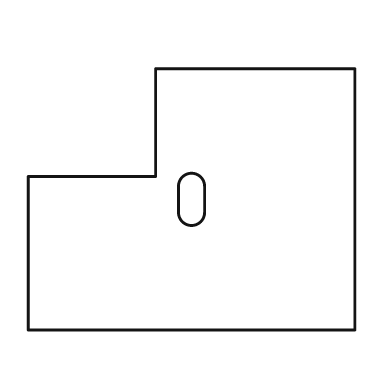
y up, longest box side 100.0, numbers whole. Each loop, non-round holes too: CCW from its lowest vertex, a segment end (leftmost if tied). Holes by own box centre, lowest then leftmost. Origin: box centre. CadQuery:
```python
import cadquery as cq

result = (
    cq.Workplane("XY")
    .moveTo(-50.0, -40.0)
    .lineTo(50.0, -40.0)
    .lineTo(50.0, 40.0)
    .lineTo(-11.0, 40.0)
    .lineTo(-11.0, 7.0)
    .lineTo(-50.0, 7.0)
    .close()
    .moveTo(-4.0, -4.0)
    .threePointArc((0.0, -8.0), (4.0, -4.0))
    .lineTo(4.0, 4.0)
    .threePointArc((0.0, 8.0), (-4.0, 4.0))
    .close()
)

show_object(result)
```